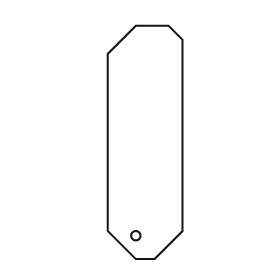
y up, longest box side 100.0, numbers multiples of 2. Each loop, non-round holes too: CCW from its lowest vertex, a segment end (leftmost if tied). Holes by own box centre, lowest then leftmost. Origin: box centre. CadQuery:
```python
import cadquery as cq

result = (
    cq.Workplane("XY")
    .moveTo(-4.0, -50.0)
    .lineTo(4.0, -50.0)
    .lineTo(16.0, -38.0)
    .lineTo(16.0, 44.0)
    .lineTo(10.0, 50.0)
    .lineTo(-4.0, 50.0)
    .lineTo(-16.0, 38.0)
    .lineTo(-16.0, -38.0)
    .close()
    .moveTo(-4.0, -40.0)
    .circle(2.0)
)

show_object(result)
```